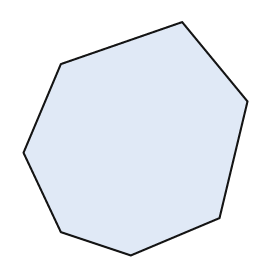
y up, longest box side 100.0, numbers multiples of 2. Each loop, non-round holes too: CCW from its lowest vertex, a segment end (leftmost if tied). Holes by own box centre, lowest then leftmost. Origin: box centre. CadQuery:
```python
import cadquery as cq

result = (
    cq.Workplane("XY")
    .moveTo(-2.0, -50.0)
    .lineTo(36.0, -34.0)
    .lineTo(48.0, 16.0)
    .lineTo(20.0, 50.0)
    .lineTo(-32.0, 32.0)
    .lineTo(-48.0, -6.0)
    .lineTo(-32.0, -40.0)
    .close()
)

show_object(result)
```